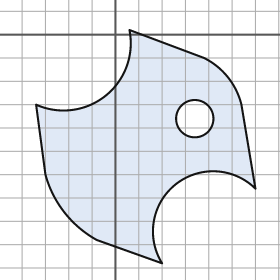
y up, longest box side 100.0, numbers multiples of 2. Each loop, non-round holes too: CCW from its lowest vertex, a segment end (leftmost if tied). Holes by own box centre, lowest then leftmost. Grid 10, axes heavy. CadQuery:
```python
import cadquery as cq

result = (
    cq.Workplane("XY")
    .moveTo(20.0, -98.0)
    .threePointArc((26.0, -64.0), (60.0, -66.0))
    .lineTo(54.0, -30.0)
    .threePointArc((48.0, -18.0), (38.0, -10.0))
    .lineTo(6.0, 2.0)
    .threePointArc((-4.0, -26.0), (-34.0, -30.0))
    .lineTo(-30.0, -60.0)
    .threePointArc((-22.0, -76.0), (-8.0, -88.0))
    .close()
    .moveTo(34.0, -36.0)
    .circle(8.0)
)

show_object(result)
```